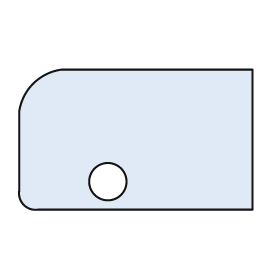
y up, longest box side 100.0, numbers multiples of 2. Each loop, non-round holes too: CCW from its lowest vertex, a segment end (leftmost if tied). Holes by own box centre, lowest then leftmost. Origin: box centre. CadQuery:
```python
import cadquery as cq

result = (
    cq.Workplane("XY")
    .moveTo(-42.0, -30.0)
    .lineTo(50.0, -30.0)
    .lineTo(50.0, 30.0)
    .lineTo(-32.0, 30.0)
    .threePointArc((-44.0, 24.0), (-50.0, 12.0))
    .lineTo(-50.0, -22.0)
    .threePointArc((-48.0, -28.0), (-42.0, -30.0))
    .close()
    .moveTo(-12.0, -18.0)
    .circle(8.0)
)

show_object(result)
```